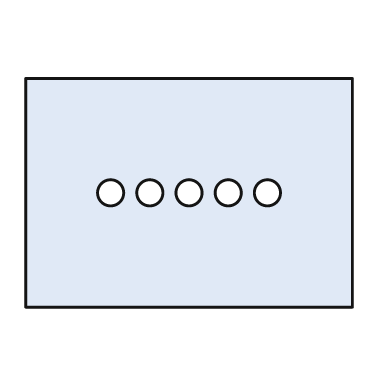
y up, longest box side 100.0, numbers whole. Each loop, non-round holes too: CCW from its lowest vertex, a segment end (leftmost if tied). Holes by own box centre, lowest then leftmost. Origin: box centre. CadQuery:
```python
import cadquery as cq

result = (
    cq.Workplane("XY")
    .moveTo(-50.0, -35.0)
    .lineTo(50.0, -35.0)
    .lineTo(50.0, 35.0)
    .lineTo(-50.0, 35.0)
    .close()
    .moveTo(-24.0, 0.0)
    .circle(4.0)
    .moveTo(-12.0, 0.0)
    .circle(4.0)
    .moveTo(0.0, 0.0)
    .circle(4.0)
    .moveTo(12.0, 0.0)
    .circle(4.0)
    .moveTo(24.0, 0.0)
    .circle(4.0)
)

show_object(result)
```